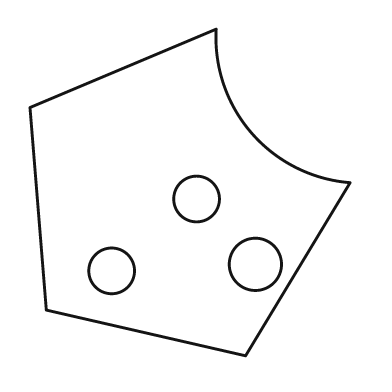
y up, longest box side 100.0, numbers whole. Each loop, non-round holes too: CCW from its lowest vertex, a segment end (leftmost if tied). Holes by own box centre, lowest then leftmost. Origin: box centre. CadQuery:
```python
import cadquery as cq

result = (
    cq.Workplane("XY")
    .moveTo(17.0, -50.0)
    .lineTo(49.0, 3.0)
    .threePointArc((19.0, 18.0), (8.0, 50.0))
    .lineTo(-49.0, 26.0)
    .lineTo(-44.0, -36.0)
    .close()
    .moveTo(-24.0, -24.0)
    .circle(7.0)
    .moveTo(20.0, -22.0)
    .circle(8.0)
    .moveTo(2.0, -2.0)
    .circle(7.0)
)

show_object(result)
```